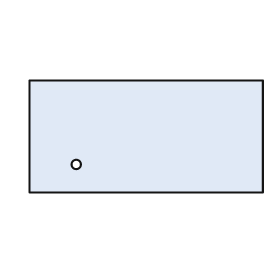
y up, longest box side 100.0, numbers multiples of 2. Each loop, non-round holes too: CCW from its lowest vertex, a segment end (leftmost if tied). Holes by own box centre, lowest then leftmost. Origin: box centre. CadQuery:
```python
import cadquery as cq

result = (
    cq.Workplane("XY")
    .moveTo(-50.0, -24.0)
    .lineTo(50.0, -24.0)
    .lineTo(50.0, 24.0)
    .lineTo(-50.0, 24.0)
    .close()
    .moveTo(-30.0, -12.0)
    .circle(2.0)
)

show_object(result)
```